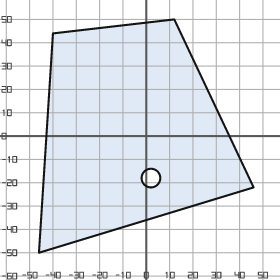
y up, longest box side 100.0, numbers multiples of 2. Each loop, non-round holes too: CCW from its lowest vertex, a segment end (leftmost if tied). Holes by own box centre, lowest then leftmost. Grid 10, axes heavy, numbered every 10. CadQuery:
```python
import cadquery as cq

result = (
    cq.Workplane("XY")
    .moveTo(-46.0, -50.0)
    .lineTo(46.0, -22.0)
    .lineTo(12.0, 50.0)
    .lineTo(-40.0, 44.0)
    .close()
    .moveTo(2.0, -18.0)
    .circle(4.0)
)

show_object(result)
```